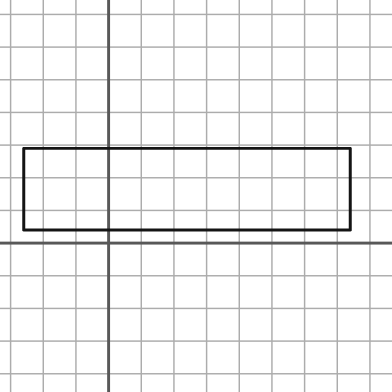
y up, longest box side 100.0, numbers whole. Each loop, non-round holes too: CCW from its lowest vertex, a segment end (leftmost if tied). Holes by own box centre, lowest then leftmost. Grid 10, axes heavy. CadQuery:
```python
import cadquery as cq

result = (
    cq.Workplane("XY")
    .moveTo(-26.0, 4.0)
    .lineTo(74.0, 4.0)
    .lineTo(74.0, 29.0)
    .lineTo(-26.0, 29.0)
    .close()
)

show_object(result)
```